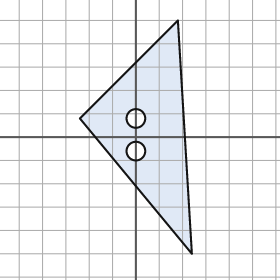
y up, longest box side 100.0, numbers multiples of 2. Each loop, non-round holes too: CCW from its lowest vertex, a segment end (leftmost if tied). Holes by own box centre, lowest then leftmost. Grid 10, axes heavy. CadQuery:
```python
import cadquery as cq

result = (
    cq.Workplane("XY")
    .moveTo(24.0, -50.0)
    .lineTo(18.0, 50.0)
    .lineTo(-24.0, 8.0)
    .close()
    .moveTo(0.0, -6.0)
    .circle(4.0)
    .moveTo(0.0, 8.0)
    .circle(4.0)
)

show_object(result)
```